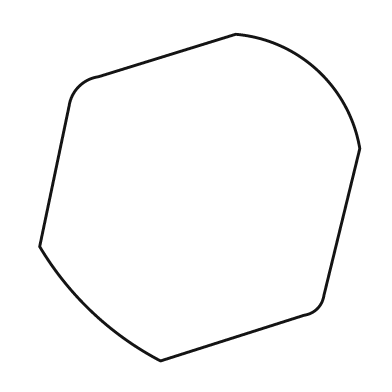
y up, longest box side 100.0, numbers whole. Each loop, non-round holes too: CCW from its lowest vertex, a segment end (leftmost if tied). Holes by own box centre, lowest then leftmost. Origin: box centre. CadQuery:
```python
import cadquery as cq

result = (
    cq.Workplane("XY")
    .moveTo(-12.0, -50.0)
    .lineTo(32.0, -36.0)
    .threePointArc((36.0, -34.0), (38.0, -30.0))
    .lineTo(49.0, 15.0)
    .threePointArc((36.0, 39.0), (11.0, 50.0))
    .lineTo(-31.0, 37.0)
    .threePointArc((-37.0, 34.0), (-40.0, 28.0))
    .lineTo(-49.0, -15.0)
    .threePointArc((-33.0, -35.0), (-12.0, -50.0))
    .close()
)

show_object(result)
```